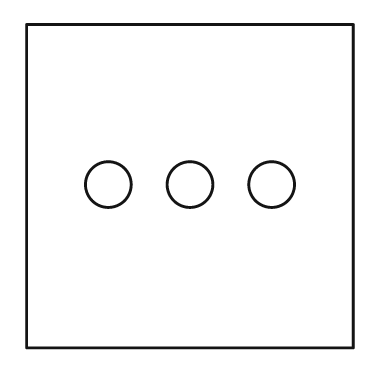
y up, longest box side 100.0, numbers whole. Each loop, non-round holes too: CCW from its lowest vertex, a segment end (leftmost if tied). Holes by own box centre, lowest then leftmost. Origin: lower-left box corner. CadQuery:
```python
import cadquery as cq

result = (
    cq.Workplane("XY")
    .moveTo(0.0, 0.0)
    .lineTo(100.0, 0.0)
    .lineTo(100.0, 99.0)
    .lineTo(0.0, 99.0)
    .close()
    .moveTo(25.0, 50.0)
    .circle(7.0)
    .moveTo(50.0, 50.0)
    .circle(7.0)
    .moveTo(75.0, 50.0)
    .circle(7.0)
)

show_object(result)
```